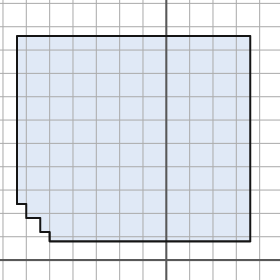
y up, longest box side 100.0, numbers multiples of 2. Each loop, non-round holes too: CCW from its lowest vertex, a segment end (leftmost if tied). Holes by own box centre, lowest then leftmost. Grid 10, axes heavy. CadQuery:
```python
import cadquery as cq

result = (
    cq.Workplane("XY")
    .moveTo(-50.0, 8.0)
    .lineTo(36.0, 8.0)
    .lineTo(36.0, 96.0)
    .lineTo(-64.0, 96.0)
    .lineTo(-64.0, 24.0)
    .lineTo(-60.0, 24.0)
    .lineTo(-60.0, 18.0)
    .lineTo(-54.0, 18.0)
    .lineTo(-54.0, 12.0)
    .lineTo(-50.0, 12.0)
    .close()
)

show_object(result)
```